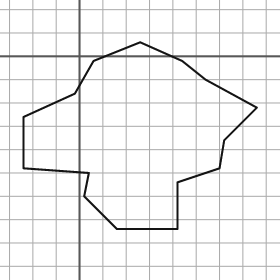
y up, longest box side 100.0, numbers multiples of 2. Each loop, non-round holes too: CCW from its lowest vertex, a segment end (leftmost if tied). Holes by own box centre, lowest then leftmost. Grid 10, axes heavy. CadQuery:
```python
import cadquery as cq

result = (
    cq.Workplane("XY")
    .moveTo(16.0, -74.0)
    .lineTo(42.0, -74.0)
    .lineTo(42.0, -54.0)
    .lineTo(60.0, -48.0)
    .lineTo(62.0, -36.0)
    .lineTo(76.0, -22.0)
    .lineTo(54.0, -10.0)
    .lineTo(44.0, -2.0)
    .lineTo(26.0, 6.0)
    .lineTo(6.0, -2.0)
    .lineTo(-2.0, -16.0)
    .lineTo(-24.0, -26.0)
    .lineTo(-24.0, -48.0)
    .lineTo(4.0, -50.0)
    .lineTo(2.0, -60.0)
    .close()
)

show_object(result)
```